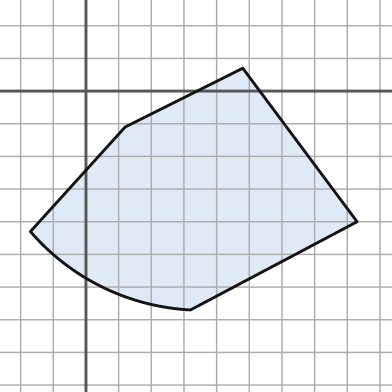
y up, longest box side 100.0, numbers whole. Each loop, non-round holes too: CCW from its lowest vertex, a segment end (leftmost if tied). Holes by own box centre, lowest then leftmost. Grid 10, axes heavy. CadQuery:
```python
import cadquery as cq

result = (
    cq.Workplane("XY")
    .moveTo(32.0, -67.0)
    .lineTo(83.0, -40.0)
    .lineTo(48.0, 7.0)
    .lineTo(12.0, -11.0)
    .lineTo(-17.0, -43.0)
    .threePointArc((5.0, -60.0), (32.0, -67.0))
    .close()
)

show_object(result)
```